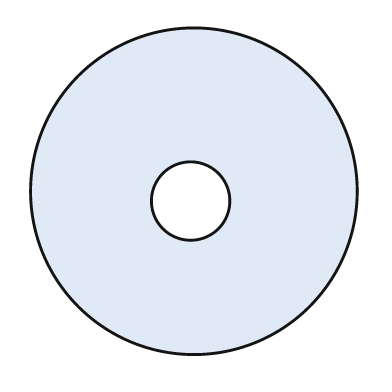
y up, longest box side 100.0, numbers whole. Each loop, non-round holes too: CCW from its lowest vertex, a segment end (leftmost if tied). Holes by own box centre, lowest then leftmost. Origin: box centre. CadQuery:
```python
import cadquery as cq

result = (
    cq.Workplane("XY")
    .moveTo(0.0, 0.0)
    .circle(50.0)
    .moveTo(-1.0, -3.0)
    .circle(12.0)
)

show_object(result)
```